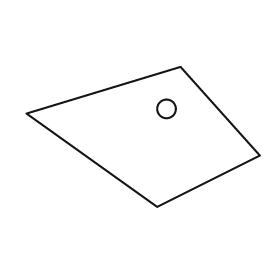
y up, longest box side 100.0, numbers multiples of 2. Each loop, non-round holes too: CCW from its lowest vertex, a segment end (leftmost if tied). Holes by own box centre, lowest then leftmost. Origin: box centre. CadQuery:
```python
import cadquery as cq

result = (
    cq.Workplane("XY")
    .moveTo(6.0, -30.0)
    .lineTo(50.0, -8.0)
    .lineTo(16.0, 30.0)
    .lineTo(-50.0, 10.0)
    .close()
    .moveTo(10.0, 12.0)
    .circle(4.0)
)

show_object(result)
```